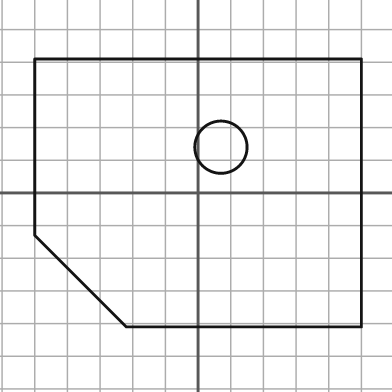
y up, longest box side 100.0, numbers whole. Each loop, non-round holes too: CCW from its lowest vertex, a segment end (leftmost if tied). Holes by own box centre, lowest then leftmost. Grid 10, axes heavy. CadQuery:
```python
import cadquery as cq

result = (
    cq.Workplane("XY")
    .moveTo(-22.0, -41.0)
    .lineTo(50.0, -41.0)
    .lineTo(50.0, 41.0)
    .lineTo(-50.0, 41.0)
    .lineTo(-50.0, -13.0)
    .close()
    .moveTo(7.0, 14.0)
    .circle(8.0)
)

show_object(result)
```